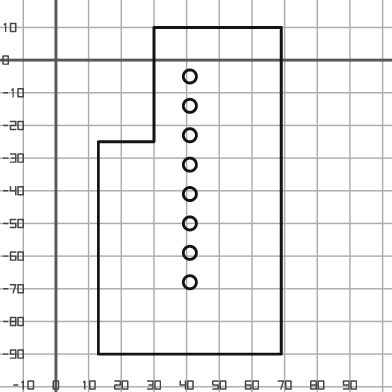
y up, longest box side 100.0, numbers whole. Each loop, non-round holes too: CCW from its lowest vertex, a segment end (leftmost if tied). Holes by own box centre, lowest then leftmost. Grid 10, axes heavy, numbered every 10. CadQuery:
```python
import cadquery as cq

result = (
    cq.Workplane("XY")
    .moveTo(13.0, -90.0)
    .lineTo(69.0, -90.0)
    .lineTo(69.0, 10.0)
    .lineTo(30.0, 10.0)
    .lineTo(30.0, -25.0)
    .lineTo(13.0, -25.0)
    .close()
    .moveTo(41.0, -68.0)
    .circle(2.0)
    .moveTo(41.0, -59.0)
    .circle(2.0)
    .moveTo(41.0, -50.0)
    .circle(2.0)
    .moveTo(41.0, -41.0)
    .circle(2.0)
    .moveTo(41.0, -32.0)
    .circle(2.0)
    .moveTo(41.0, -23.0)
    .circle(2.0)
    .moveTo(41.0, -14.0)
    .circle(2.0)
    .moveTo(41.0, -5.0)
    .circle(2.0)
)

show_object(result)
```